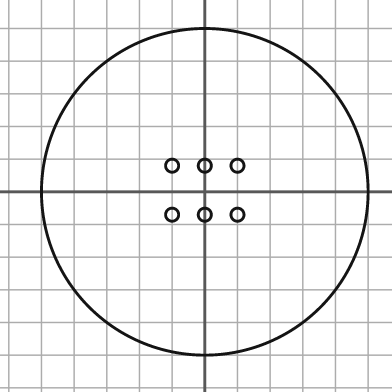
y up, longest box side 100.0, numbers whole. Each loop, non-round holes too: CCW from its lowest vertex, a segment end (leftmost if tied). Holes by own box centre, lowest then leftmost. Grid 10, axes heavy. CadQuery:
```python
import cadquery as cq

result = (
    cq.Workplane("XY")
    .moveTo(0.0, 0.0)
    .circle(50.0)
    .moveTo(-10.0, -7.0)
    .circle(2.0)
    .moveTo(0.0, -7.0)
    .circle(2.0)
    .moveTo(10.0, -7.0)
    .circle(2.0)
    .moveTo(-10.0, 8.0)
    .circle(2.0)
    .moveTo(0.0, 8.0)
    .circle(2.0)
    .moveTo(10.0, 8.0)
    .circle(2.0)
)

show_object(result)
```